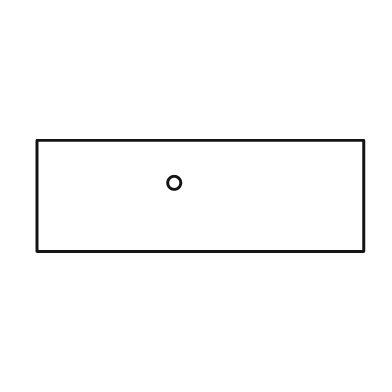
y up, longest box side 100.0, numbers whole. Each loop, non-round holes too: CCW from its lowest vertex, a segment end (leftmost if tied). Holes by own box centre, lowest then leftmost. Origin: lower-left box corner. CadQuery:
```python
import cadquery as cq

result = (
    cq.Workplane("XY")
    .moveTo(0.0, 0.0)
    .lineTo(100.0, 0.0)
    .lineTo(100.0, 34.0)
    .lineTo(0.0, 34.0)
    .close()
    .moveTo(42.0, 21.0)
    .circle(2.0)
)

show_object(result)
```